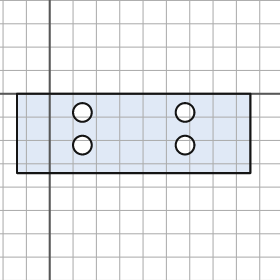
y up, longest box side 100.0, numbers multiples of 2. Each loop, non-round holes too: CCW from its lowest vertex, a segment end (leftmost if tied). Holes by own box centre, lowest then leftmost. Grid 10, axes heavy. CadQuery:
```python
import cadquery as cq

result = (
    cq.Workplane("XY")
    .moveTo(-14.0, -34.0)
    .lineTo(86.0, -34.0)
    .lineTo(86.0, 0.0)
    .lineTo(-14.0, 0.0)
    .close()
    .moveTo(14.0, -22.0)
    .circle(4.0)
    .moveTo(58.0, -22.0)
    .circle(4.0)
    .moveTo(14.0, -8.0)
    .circle(4.0)
    .moveTo(58.0, -8.0)
    .circle(4.0)
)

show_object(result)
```